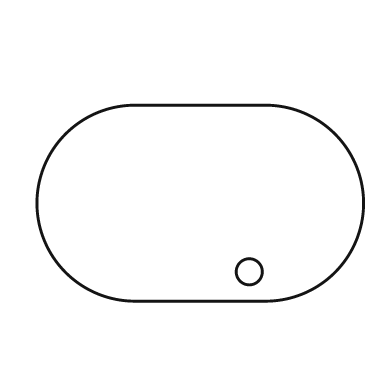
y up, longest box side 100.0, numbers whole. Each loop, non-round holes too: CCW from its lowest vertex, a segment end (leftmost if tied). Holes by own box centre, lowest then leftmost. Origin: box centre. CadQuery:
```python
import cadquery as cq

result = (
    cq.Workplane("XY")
    .moveTo(-20.0, -30.0)
    .lineTo(20.0, -30.0)
    .threePointArc((50.0, 0.0), (20.0, 30.0))
    .lineTo(-20.0, 30.0)
    .threePointArc((-50.0, 0.0), (-20.0, -30.0))
    .close()
    .moveTo(15.0, -21.0)
    .circle(4.0)
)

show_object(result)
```